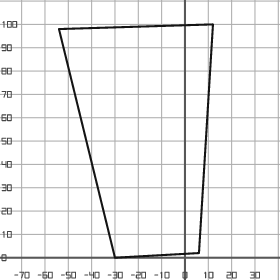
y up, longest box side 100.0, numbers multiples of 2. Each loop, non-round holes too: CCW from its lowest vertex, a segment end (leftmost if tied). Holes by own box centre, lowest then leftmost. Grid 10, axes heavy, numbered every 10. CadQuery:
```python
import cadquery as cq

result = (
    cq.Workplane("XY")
    .moveTo(-30.0, 0.0)
    .lineTo(6.0, 2.0)
    .lineTo(12.0, 100.0)
    .lineTo(-54.0, 98.0)
    .close()
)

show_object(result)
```